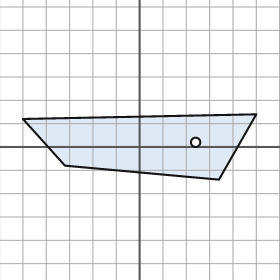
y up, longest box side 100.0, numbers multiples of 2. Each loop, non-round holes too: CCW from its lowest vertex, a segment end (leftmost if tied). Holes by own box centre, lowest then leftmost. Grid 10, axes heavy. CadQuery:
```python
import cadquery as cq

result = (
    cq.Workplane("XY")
    .moveTo(34.0, -14.0)
    .lineTo(50.0, 14.0)
    .lineTo(-50.0, 12.0)
    .lineTo(-32.0, -8.0)
    .close()
    .moveTo(24.0, 2.0)
    .circle(2.0)
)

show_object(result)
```